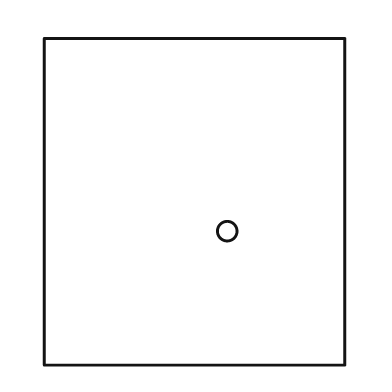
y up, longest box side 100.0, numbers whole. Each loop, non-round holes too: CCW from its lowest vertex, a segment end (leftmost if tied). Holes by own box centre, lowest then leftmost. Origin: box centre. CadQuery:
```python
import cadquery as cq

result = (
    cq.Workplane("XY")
    .moveTo(-46.0, -50.0)
    .lineTo(46.0, -50.0)
    .lineTo(46.0, 50.0)
    .lineTo(-46.0, 50.0)
    .close()
    .moveTo(10.0, -9.0)
    .circle(3.0)
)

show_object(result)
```